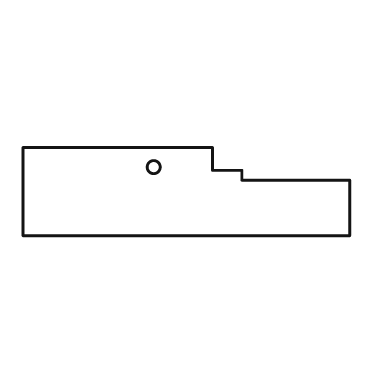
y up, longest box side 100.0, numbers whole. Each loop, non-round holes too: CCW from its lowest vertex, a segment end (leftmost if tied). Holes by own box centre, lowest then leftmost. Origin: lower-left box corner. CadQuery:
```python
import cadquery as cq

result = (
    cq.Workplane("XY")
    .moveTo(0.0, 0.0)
    .lineTo(100.0, 0.0)
    .lineTo(100.0, 17.0)
    .lineTo(67.0, 17.0)
    .lineTo(67.0, 20.0)
    .lineTo(58.0, 20.0)
    .lineTo(58.0, 27.0)
    .lineTo(0.0, 27.0)
    .close()
    .moveTo(40.0, 21.0)
    .circle(2.0)
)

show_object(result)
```